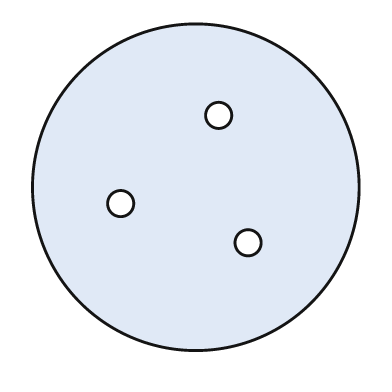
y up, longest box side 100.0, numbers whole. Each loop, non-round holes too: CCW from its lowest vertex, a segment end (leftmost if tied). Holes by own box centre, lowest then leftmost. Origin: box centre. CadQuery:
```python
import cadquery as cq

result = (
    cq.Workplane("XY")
    .moveTo(0.0, 0.0)
    .circle(50.0)
    .moveTo(16.0, -17.0)
    .circle(4.0)
    .moveTo(-23.0, -5.0)
    .circle(4.0)
    .moveTo(7.0, 22.0)
    .circle(4.0)
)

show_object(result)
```